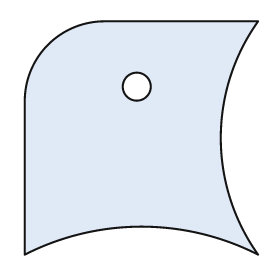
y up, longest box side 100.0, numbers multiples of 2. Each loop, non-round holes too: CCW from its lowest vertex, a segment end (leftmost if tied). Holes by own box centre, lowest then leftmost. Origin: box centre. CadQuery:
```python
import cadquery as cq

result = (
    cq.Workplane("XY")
    .moveTo(-50.0, -50.0)
    .threePointArc((0.0, -38.0), (50.0, -50.0))
    .threePointArc((34.0, 0.0), (50.0, 50.0))
    .lineTo(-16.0, 50.0)
    .threePointArc((-40.0, 40.0), (-50.0, 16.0))
    .close()
    .moveTo(-2.0, 22.0)
    .circle(6.0)
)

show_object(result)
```